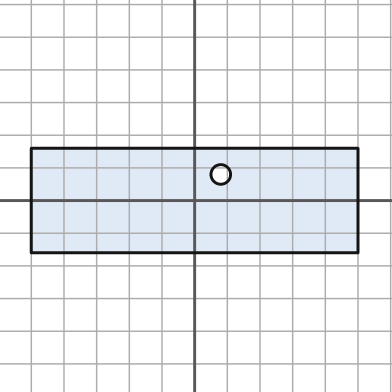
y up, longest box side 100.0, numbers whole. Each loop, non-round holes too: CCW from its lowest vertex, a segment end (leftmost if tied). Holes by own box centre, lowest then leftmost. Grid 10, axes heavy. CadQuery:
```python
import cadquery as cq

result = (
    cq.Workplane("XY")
    .moveTo(-50.0, -16.0)
    .lineTo(50.0, -16.0)
    .lineTo(50.0, 16.0)
    .lineTo(-50.0, 16.0)
    .close()
    .moveTo(8.0, 8.0)
    .circle(3.0)
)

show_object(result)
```